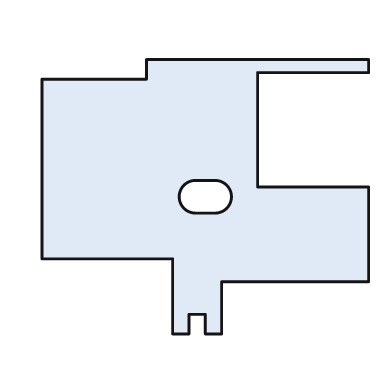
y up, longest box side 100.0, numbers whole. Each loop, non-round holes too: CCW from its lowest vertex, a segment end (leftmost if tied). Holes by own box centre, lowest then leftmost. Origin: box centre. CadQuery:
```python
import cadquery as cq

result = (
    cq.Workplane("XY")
    .moveTo(-10.0, -42.0)
    .lineTo(-5.0, -42.0)
    .lineTo(-5.0, -36.0)
    .lineTo(0.0, -36.0)
    .lineTo(0.0, -42.0)
    .lineTo(5.0, -42.0)
    .lineTo(5.0, -26.0)
    .lineTo(50.0, -26.0)
    .lineTo(50.0, 3.0)
    .lineTo(16.0, 3.0)
    .lineTo(16.0, 38.0)
    .lineTo(50.0, 38.0)
    .lineTo(50.0, 42.0)
    .lineTo(-18.0, 42.0)
    .lineTo(-18.0, 36.0)
    .lineTo(-50.0, 36.0)
    .lineTo(-50.0, -19.0)
    .lineTo(-10.0, -19.0)
    .close()
    .moveTo(-3.0, -5.0)
    .lineTo(3.0, -5.0)
    .threePointArc((8.0, 0.0), (3.0, 5.0))
    .lineTo(-3.0, 5.0)
    .threePointArc((-8.0, 0.0), (-3.0, -5.0))
    .close()
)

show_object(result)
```